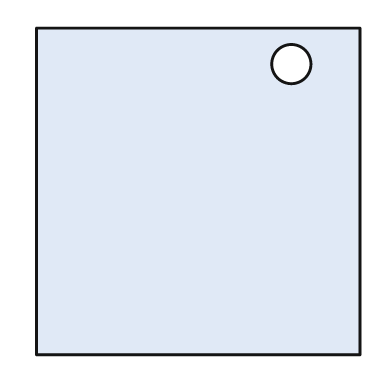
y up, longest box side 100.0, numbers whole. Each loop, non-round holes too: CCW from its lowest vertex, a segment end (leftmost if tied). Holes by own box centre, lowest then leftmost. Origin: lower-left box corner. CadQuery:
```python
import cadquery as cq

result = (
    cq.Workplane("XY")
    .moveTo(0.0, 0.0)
    .lineTo(99.0, 0.0)
    .lineTo(99.0, 100.0)
    .lineTo(0.0, 100.0)
    .close()
    .moveTo(78.0, 89.0)
    .circle(6.0)
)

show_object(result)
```